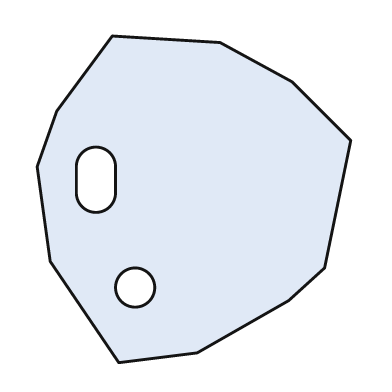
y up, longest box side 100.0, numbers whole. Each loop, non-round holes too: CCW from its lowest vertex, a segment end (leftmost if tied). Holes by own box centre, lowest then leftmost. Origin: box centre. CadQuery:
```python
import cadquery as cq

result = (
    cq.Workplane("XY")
    .moveTo(-23.0, -50.0)
    .lineTo(1.0, -47.0)
    .lineTo(29.0, -31.0)
    .lineTo(40.0, -21.0)
    .lineTo(48.0, 18.0)
    .lineTo(30.0, 36.0)
    .lineTo(8.0, 48.0)
    .lineTo(-25.0, 50.0)
    .lineTo(-42.0, 27.0)
    .lineTo(-48.0, 10.0)
    .lineTo(-44.0, -19.0)
    .close()
    .moveTo(-18.0, -27.0)
    .circle(6.0)
    .moveTo(-36.0, 2.0)
    .threePointArc((-30.0, -4.0), (-24.0, 2.0))
    .lineTo(-24.0, 10.0)
    .threePointArc((-30.0, 16.0), (-36.0, 10.0))
    .close()
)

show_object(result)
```